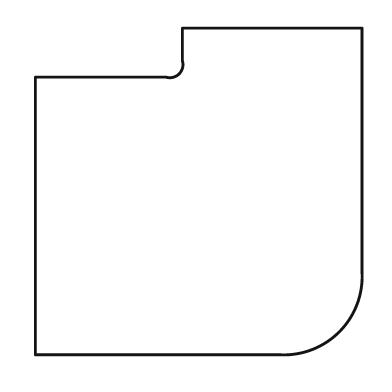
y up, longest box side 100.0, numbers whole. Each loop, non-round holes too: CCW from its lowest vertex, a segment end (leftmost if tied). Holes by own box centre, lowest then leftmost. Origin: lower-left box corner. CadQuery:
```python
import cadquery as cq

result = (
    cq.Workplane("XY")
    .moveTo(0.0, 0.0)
    .lineTo(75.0, 0.0)
    .threePointArc((93.0, 7.0), (100.0, 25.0))
    .lineTo(100.0, 100.0)
    .lineTo(45.0, 100.0)
    .lineTo(45.0, 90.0)
    .threePointArc((44.0, 86.0), (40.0, 85.0))
    .lineTo(0.0, 85.0)
    .close()
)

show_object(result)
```